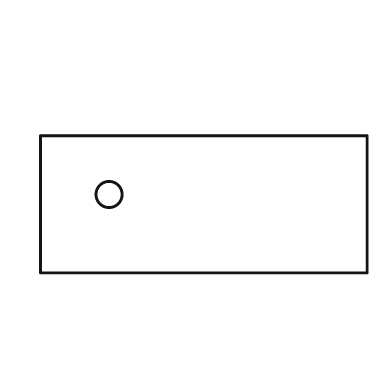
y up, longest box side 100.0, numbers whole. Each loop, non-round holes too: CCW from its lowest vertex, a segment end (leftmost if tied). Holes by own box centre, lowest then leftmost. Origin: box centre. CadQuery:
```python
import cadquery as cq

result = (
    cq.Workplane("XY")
    .moveTo(-50.0, -21.0)
    .lineTo(50.0, -21.0)
    .lineTo(50.0, 21.0)
    .lineTo(-50.0, 21.0)
    .close()
    .moveTo(-29.0, 3.0)
    .circle(4.0)
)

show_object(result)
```